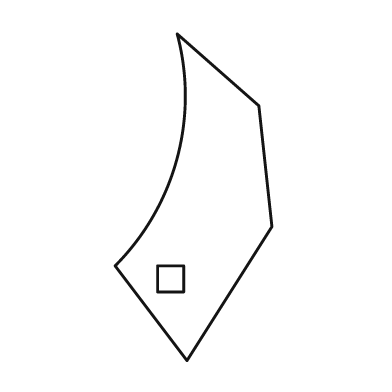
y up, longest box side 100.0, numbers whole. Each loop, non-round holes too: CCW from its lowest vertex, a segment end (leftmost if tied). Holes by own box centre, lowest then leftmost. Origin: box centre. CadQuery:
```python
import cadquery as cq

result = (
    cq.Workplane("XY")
    .moveTo(-2.0, -50.0)
    .lineTo(24.0, -9.0)
    .lineTo(20.0, 28.0)
    .lineTo(-5.0, 50.0)
    .threePointArc((-5.0, 12.0), (-24.0, -21.0))
    .close()
    .moveTo(-11.0, -29.0)
    .lineTo(-3.0, -29.0)
    .lineTo(-3.0, -21.0)
    .lineTo(-11.0, -21.0)
    .close()
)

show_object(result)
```